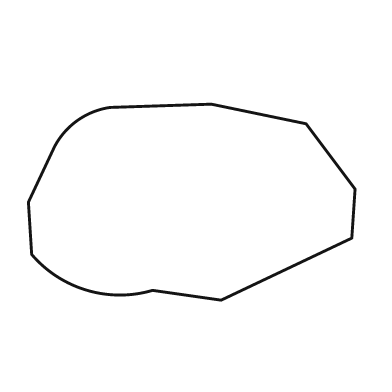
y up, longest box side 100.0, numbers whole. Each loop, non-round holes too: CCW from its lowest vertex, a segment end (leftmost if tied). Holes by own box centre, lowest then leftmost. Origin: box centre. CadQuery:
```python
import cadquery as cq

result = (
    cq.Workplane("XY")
    .moveTo(9.0, -30.0)
    .lineTo(49.0, -11.0)
    .lineTo(50.0, 4.0)
    .lineTo(35.0, 24.0)
    .lineTo(6.0, 30.0)
    .lineTo(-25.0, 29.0)
    .threePointArc((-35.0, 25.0), (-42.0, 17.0))
    .lineTo(-50.0, 0.0)
    .lineTo(-49.0, -16.0)
    .threePointArc((-32.0, -27.0), (-12.0, -27.0))
    .close()
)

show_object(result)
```